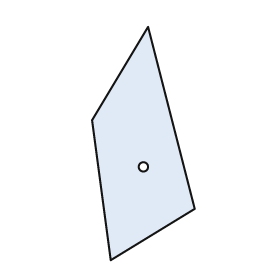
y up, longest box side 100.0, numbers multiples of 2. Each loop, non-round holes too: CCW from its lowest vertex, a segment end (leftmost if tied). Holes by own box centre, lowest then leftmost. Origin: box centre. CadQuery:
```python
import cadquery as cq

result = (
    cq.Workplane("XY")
    .moveTo(-14.0, -50.0)
    .lineTo(22.0, -28.0)
    .lineTo(2.0, 50.0)
    .lineTo(-22.0, 10.0)
    .close()
    .moveTo(0.0, -10.0)
    .circle(2.0)
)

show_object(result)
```